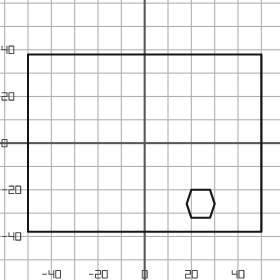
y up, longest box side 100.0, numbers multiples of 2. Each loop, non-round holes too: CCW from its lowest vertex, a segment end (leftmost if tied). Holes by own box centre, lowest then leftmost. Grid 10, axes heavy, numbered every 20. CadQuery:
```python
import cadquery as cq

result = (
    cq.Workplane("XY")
    .moveTo(-50.0, -38.0)
    .lineTo(50.0, -38.0)
    .lineTo(50.0, 38.0)
    .lineTo(-50.0, 38.0)
    .close()
    .moveTo(20.0, -32.0)
    .lineTo(28.0, -32.0)
    .lineTo(30.0, -26.0)
    .lineTo(28.0, -20.0)
    .lineTo(20.0, -20.0)
    .lineTo(18.0, -26.0)
    .close()
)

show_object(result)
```